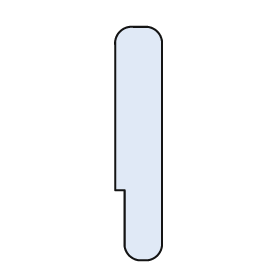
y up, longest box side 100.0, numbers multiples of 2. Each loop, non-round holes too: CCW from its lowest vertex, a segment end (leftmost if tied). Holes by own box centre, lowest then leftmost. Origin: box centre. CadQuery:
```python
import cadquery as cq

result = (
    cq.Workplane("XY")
    .moveTo(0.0, -50.0)
    .lineTo(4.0, -50.0)
    .threePointArc((8.0, -48.0), (10.0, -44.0))
    .lineTo(10.0, 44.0)
    .threePointArc((8.0, 48.0), (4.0, 50.0))
    .lineTo(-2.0, 50.0)
    .threePointArc((-8.0, 48.0), (-10.0, 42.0))
    .lineTo(-10.0, -20.0)
    .lineTo(-6.0, -20.0)
    .lineTo(-6.0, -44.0)
    .threePointArc((-4.0, -48.0), (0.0, -50.0))
    .close()
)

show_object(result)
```